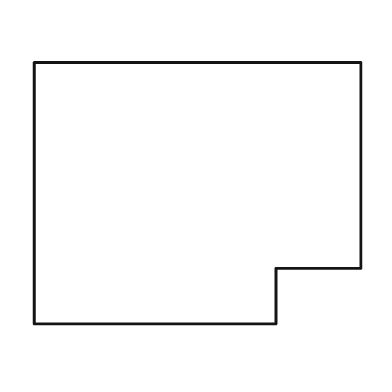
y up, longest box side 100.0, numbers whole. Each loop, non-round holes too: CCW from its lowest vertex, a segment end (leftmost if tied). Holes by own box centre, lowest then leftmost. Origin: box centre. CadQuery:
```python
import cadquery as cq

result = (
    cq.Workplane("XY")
    .moveTo(-50.0, -40.0)
    .lineTo(24.0, -40.0)
    .lineTo(24.0, -23.0)
    .lineTo(50.0, -23.0)
    .lineTo(50.0, 40.0)
    .lineTo(-50.0, 40.0)
    .close()
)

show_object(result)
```